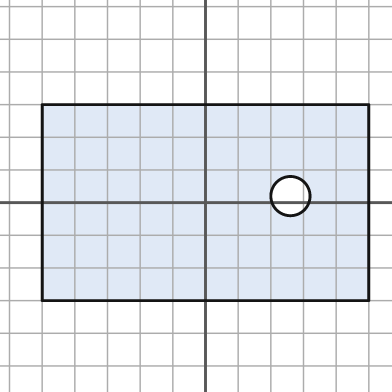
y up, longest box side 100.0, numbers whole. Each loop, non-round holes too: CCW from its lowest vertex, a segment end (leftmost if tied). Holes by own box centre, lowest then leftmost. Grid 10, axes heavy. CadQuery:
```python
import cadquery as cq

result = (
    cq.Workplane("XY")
    .moveTo(-50.0, -30.0)
    .lineTo(50.0, -30.0)
    .lineTo(50.0, 30.0)
    .lineTo(-50.0, 30.0)
    .close()
    .moveTo(26.0, 2.0)
    .circle(6.0)
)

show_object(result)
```